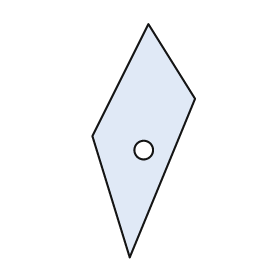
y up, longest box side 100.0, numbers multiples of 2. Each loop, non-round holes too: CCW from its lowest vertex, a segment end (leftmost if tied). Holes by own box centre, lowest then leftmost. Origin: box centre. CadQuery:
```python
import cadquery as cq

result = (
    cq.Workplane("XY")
    .moveTo(-6.0, -50.0)
    .lineTo(22.0, 18.0)
    .lineTo(2.0, 50.0)
    .lineTo(-22.0, 2.0)
    .close()
    .moveTo(0.0, -4.0)
    .circle(4.0)
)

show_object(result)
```